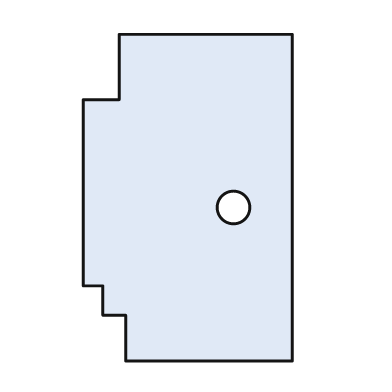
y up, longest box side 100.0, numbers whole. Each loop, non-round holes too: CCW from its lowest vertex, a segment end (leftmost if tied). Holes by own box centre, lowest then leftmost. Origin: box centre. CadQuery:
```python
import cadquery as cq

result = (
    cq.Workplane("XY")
    .moveTo(-19.0, -50.0)
    .lineTo(32.0, -50.0)
    .lineTo(32.0, 50.0)
    .lineTo(-21.0, 50.0)
    .lineTo(-21.0, 30.0)
    .lineTo(-32.0, 30.0)
    .lineTo(-32.0, -27.0)
    .lineTo(-26.0, -27.0)
    .lineTo(-26.0, -36.0)
    .lineTo(-19.0, -36.0)
    .close()
    .moveTo(14.0, -3.0)
    .circle(5.0)
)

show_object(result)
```